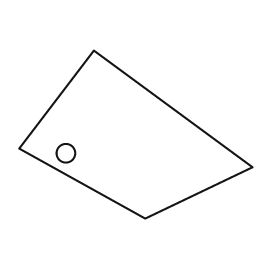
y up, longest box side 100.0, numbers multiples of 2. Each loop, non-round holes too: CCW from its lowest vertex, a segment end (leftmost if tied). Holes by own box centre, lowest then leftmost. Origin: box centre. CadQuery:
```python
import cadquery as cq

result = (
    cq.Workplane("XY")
    .moveTo(4.0, -36.0)
    .lineTo(50.0, -14.0)
    .lineTo(-18.0, 36.0)
    .lineTo(-50.0, -6.0)
    .close()
    .moveTo(-30.0, -8.0)
    .circle(4.0)
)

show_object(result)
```